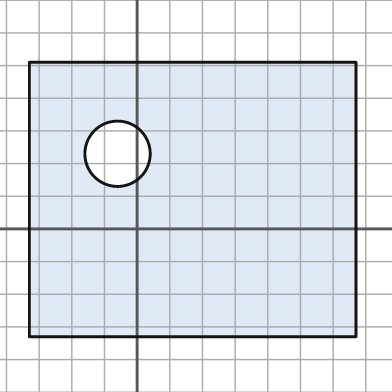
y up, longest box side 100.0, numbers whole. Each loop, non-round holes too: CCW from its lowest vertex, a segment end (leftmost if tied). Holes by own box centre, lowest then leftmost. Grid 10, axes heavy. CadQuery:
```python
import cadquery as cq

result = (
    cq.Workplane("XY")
    .moveTo(-33.0, -33.0)
    .lineTo(67.0, -33.0)
    .lineTo(67.0, 51.0)
    .lineTo(-33.0, 51.0)
    .close()
    .moveTo(-6.0, 23.0)
    .circle(10.0)
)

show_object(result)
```